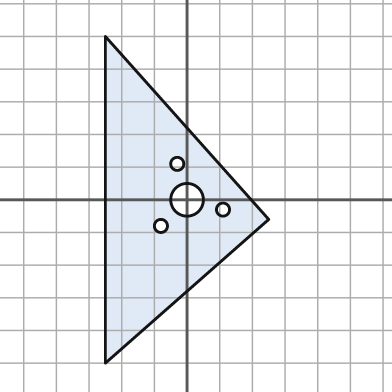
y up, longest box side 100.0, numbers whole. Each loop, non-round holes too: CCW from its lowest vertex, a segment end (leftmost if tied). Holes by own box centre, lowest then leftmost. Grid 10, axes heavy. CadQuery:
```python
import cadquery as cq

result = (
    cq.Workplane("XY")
    .moveTo(-25.0, -50.0)
    .lineTo(25.0, -6.0)
    .lineTo(-25.0, 50.0)
    .close()
    .moveTo(-8.0, -8.0)
    .circle(2.0)
    .moveTo(11.0, -3.0)
    .circle(2.0)
    .moveTo(0.0, 0.0)
    .circle(5.0)
    .moveTo(-3.0, 11.0)
    .circle(2.0)
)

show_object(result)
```